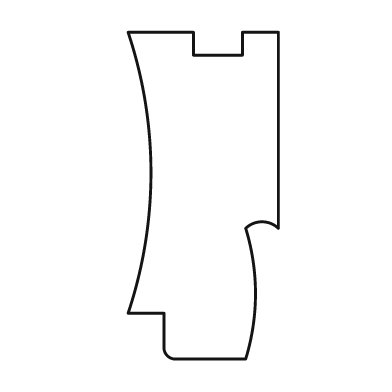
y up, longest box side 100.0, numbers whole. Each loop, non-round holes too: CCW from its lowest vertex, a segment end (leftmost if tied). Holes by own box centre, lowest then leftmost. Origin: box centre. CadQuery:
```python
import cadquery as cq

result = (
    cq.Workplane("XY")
    .moveTo(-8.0, -50.0)
    .lineTo(13.0, -50.0)
    .threePointArc((16.0, -30.0), (13.0, -10.0))
    .threePointArc((18.0, -8.0), (23.0, -10.0))
    .lineTo(23.0, 50.0)
    .lineTo(12.0, 50.0)
    .lineTo(12.0, 43.0)
    .lineTo(-3.0, 43.0)
    .lineTo(-3.0, 50.0)
    .lineTo(-23.0, 50.0)
    .threePointArc((-16.0, 7.0), (-23.0, -36.0))
    .lineTo(-12.0, -36.0)
    .lineTo(-12.0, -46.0)
    .threePointArc((-11.0, -49.0), (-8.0, -50.0))
    .close()
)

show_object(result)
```